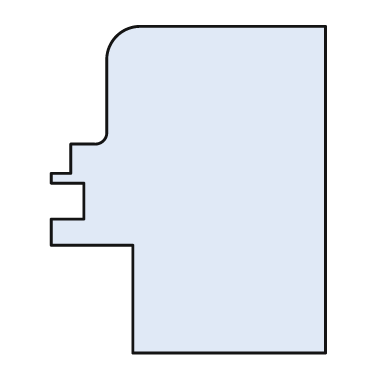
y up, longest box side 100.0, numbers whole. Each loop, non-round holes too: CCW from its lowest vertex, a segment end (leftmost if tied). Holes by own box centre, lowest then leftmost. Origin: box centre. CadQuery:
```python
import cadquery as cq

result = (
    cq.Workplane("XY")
    .moveTo(-17.0, -50.0)
    .lineTo(42.0, -50.0)
    .lineTo(42.0, 50.0)
    .lineTo(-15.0, 50.0)
    .threePointArc((-22.0, 47.0), (-25.0, 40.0))
    .lineTo(-25.0, 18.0)
    .threePointArc((-26.0, 15.0), (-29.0, 14.0))
    .lineTo(-36.0, 14.0)
    .lineTo(-36.0, 5.0)
    .lineTo(-42.0, 5.0)
    .lineTo(-42.0, 2.0)
    .lineTo(-32.0, 2.0)
    .lineTo(-32.0, -9.0)
    .lineTo(-42.0, -9.0)
    .lineTo(-42.0, -17.0)
    .lineTo(-17.0, -17.0)
    .close()
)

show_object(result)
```